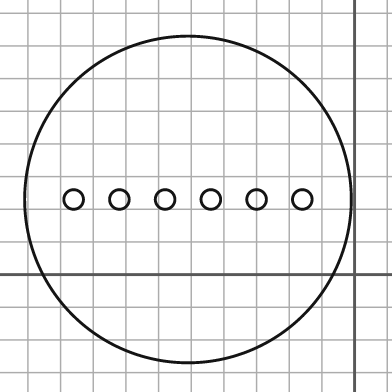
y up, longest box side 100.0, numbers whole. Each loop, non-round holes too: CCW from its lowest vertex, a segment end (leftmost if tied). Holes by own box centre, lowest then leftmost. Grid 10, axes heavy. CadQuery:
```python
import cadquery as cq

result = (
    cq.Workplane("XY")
    .moveTo(-51.0, 23.0)
    .circle(50.0)
    .moveTo(-86.0, 23.0)
    .circle(3.0)
    .moveTo(-72.0, 23.0)
    .circle(3.0)
    .moveTo(-58.0, 23.0)
    .circle(3.0)
    .moveTo(-44.0, 23.0)
    .circle(3.0)
    .moveTo(-30.0, 23.0)
    .circle(3.0)
    .moveTo(-16.0, 23.0)
    .circle(3.0)
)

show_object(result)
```